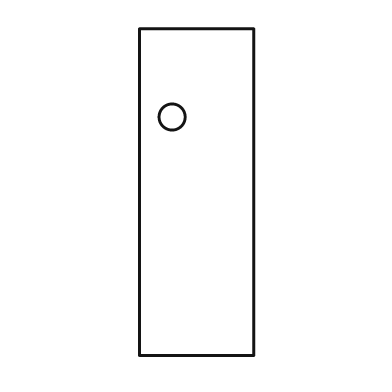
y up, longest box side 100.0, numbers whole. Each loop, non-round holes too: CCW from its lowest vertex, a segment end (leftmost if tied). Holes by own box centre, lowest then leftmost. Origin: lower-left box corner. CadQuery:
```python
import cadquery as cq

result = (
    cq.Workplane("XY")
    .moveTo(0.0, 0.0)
    .lineTo(35.0, 0.0)
    .lineTo(35.0, 100.0)
    .lineTo(0.0, 100.0)
    .close()
    .moveTo(10.0, 73.0)
    .circle(4.0)
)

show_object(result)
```